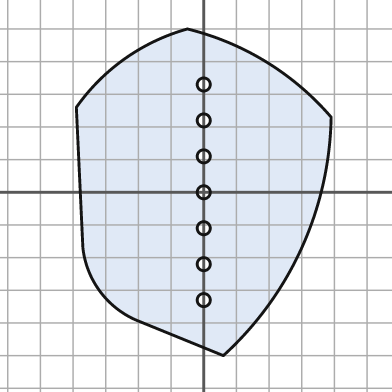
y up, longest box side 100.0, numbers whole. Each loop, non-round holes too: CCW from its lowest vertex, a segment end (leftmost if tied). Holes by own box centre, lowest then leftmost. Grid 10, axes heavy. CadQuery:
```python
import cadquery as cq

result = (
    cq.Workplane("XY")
    .moveTo(6.0, -50.0)
    .threePointArc((30.0, -17.0), (39.0, 23.0))
    .threePointArc((19.0, 40.0), (-5.0, 50.0))
    .threePointArc((-24.0, 41.0), (-39.0, 26.0))
    .lineTo(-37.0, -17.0)
    .threePointArc((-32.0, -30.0), (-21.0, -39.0))
    .close()
    .moveTo(0.0, -33.0)
    .circle(2.0)
    .moveTo(0.0, -22.0)
    .circle(2.0)
    .moveTo(0.0, -11.0)
    .circle(2.0)
    .moveTo(0.0, 0.0)
    .circle(2.0)
    .moveTo(0.0, 11.0)
    .circle(2.0)
    .moveTo(0.0, 22.0)
    .circle(2.0)
    .moveTo(0.0, 33.0)
    .circle(2.0)
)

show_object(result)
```